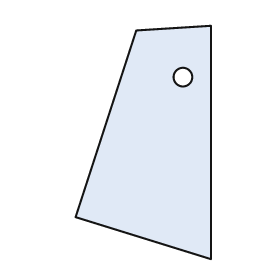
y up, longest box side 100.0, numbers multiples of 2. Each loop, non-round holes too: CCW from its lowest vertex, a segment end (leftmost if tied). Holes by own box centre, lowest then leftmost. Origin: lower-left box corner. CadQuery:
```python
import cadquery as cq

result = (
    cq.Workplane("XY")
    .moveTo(58.0, 0.0)
    .lineTo(58.0, 100.0)
    .lineTo(26.0, 98.0)
    .lineTo(0.0, 18.0)
    .close()
    .moveTo(46.0, 78.0)
    .circle(4.0)
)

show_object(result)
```